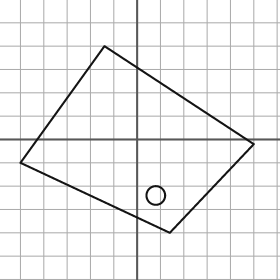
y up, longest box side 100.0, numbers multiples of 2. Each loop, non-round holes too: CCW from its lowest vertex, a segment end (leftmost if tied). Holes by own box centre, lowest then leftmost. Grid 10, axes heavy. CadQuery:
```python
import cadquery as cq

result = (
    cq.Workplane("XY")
    .moveTo(14.0, -40.0)
    .lineTo(50.0, -2.0)
    .lineTo(-14.0, 40.0)
    .lineTo(-50.0, -10.0)
    .close()
    .moveTo(8.0, -24.0)
    .circle(4.0)
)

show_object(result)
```